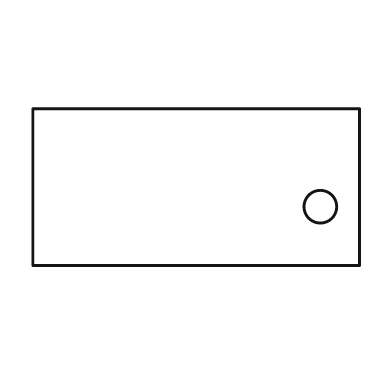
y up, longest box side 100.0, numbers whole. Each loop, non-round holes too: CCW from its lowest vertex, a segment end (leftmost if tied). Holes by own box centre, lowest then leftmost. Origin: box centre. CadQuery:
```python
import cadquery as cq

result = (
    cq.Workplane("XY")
    .moveTo(-50.0, -24.0)
    .lineTo(50.0, -24.0)
    .lineTo(50.0, 24.0)
    .lineTo(-50.0, 24.0)
    .close()
    .moveTo(38.0, -6.0)
    .circle(5.0)
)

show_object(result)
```